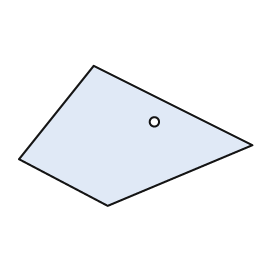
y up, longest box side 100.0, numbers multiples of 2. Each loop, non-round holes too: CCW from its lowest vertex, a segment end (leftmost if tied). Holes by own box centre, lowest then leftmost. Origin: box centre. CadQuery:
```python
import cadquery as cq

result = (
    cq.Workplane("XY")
    .moveTo(-12.0, -30.0)
    .lineTo(50.0, -4.0)
    .lineTo(-18.0, 30.0)
    .lineTo(-50.0, -10.0)
    .close()
    .moveTo(8.0, 6.0)
    .circle(2.0)
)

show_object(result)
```